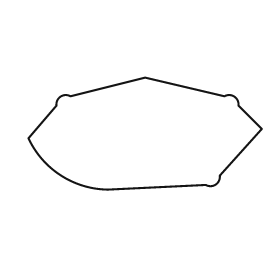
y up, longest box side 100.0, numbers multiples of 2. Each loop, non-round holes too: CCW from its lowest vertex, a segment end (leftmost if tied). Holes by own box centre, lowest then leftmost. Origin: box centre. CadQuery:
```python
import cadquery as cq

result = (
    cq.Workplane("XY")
    .moveTo(-16.0, -24.0)
    .lineTo(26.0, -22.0)
    .threePointArc((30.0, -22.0), (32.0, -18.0))
    .lineTo(50.0, 2.0)
    .lineTo(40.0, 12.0)
    .threePointArc((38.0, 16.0), (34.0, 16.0))
    .lineTo(0.0, 24.0)
    .lineTo(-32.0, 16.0)
    .threePointArc((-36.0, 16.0), (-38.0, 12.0))
    .lineTo(-50.0, -2.0)
    .threePointArc((-36.0, -18.0), (-16.0, -24.0))
    .close()
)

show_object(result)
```